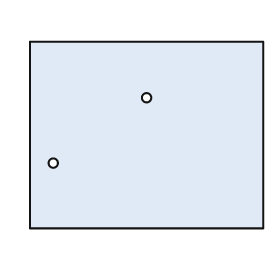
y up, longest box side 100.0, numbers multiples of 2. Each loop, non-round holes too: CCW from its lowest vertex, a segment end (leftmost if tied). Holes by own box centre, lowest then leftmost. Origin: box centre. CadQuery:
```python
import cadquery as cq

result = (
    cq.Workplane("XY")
    .moveTo(-50.0, -40.0)
    .lineTo(50.0, -40.0)
    .lineTo(50.0, 40.0)
    .lineTo(-50.0, 40.0)
    .close()
    .moveTo(-40.0, -12.0)
    .circle(2.0)
    .moveTo(0.0, 16.0)
    .circle(2.0)
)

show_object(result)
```